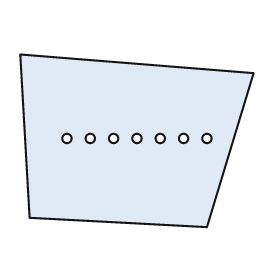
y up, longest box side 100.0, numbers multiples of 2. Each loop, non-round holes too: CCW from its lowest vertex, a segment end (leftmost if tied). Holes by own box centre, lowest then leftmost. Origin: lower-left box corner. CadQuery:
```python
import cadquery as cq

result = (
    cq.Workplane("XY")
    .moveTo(80.0, 0.0)
    .lineTo(100.0, 66.0)
    .lineTo(0.0, 74.0)
    .lineTo(4.0, 4.0)
    .close()
    .moveTo(20.0, 38.0)
    .circle(2.0)
    .moveTo(30.0, 38.0)
    .circle(2.0)
    .moveTo(40.0, 38.0)
    .circle(2.0)
    .moveTo(50.0, 38.0)
    .circle(2.0)
    .moveTo(60.0, 38.0)
    .circle(2.0)
    .moveTo(70.0, 38.0)
    .circle(2.0)
    .moveTo(80.0, 38.0)
    .circle(2.0)
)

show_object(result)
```